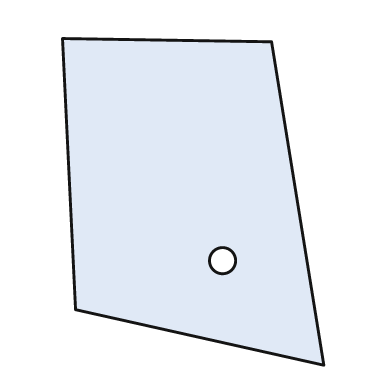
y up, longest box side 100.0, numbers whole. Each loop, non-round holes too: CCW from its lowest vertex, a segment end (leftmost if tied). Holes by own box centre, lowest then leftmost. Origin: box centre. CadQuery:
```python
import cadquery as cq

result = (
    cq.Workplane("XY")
    .moveTo(40.0, -50.0)
    .lineTo(24.0, 49.0)
    .lineTo(-40.0, 50.0)
    .lineTo(-36.0, -33.0)
    .close()
    .moveTo(9.0, -18.0)
    .circle(4.0)
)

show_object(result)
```